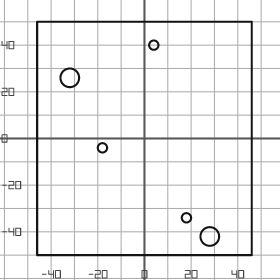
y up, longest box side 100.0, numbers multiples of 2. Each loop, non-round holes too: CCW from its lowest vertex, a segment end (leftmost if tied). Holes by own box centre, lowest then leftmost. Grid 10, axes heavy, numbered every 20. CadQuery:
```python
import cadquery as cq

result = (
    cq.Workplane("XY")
    .moveTo(-46.0, -50.0)
    .lineTo(46.0, -50.0)
    .lineTo(46.0, 50.0)
    .lineTo(-46.0, 50.0)
    .close()
    .moveTo(28.0, -42.0)
    .circle(4.0)
    .moveTo(18.0, -34.0)
    .circle(2.0)
    .moveTo(-18.0, -4.0)
    .circle(2.0)
    .moveTo(-32.0, 26.0)
    .circle(4.0)
    .moveTo(4.0, 40.0)
    .circle(2.0)
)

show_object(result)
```